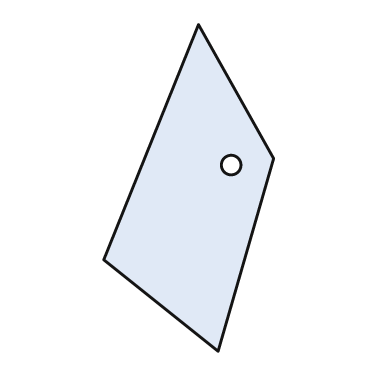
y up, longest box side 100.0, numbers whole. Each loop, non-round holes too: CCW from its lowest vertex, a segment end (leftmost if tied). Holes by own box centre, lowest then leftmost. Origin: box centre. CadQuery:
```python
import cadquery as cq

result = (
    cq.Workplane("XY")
    .moveTo(9.0, -50.0)
    .lineTo(26.0, 9.0)
    .lineTo(3.0, 50.0)
    .lineTo(-26.0, -22.0)
    .close()
    .moveTo(13.0, 7.0)
    .circle(3.0)
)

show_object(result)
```